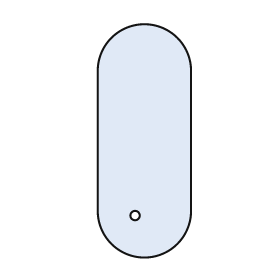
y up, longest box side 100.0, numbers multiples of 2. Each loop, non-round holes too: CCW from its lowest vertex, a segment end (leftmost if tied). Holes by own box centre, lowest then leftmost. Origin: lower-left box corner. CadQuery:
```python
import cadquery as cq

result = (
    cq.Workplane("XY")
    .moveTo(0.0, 20.0)
    .threePointArc((20.0, 0.0), (40.0, 20.0))
    .lineTo(40.0, 80.0)
    .threePointArc((20.0, 100.0), (0.0, 80.0))
    .close()
    .moveTo(16.0, 18.0)
    .circle(2.0)
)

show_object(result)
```